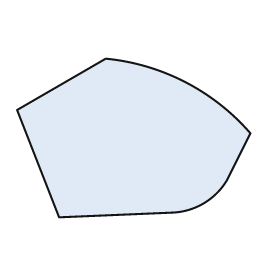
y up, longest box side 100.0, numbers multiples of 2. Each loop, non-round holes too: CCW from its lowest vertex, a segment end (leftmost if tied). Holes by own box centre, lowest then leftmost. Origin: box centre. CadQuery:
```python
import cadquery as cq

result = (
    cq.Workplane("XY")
    .moveTo(-32.0, -34.0)
    .lineTo(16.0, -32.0)
    .threePointArc((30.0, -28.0), (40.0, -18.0))
    .lineTo(50.0, 2.0)
    .threePointArc((22.0, 24.0), (-12.0, 34.0))
    .lineTo(-50.0, 12.0)
    .close()
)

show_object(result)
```